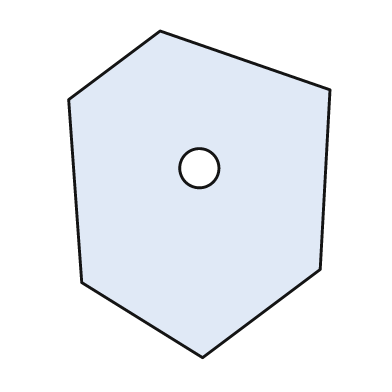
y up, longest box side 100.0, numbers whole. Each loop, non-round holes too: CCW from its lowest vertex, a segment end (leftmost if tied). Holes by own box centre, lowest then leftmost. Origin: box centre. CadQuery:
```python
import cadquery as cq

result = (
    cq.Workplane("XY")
    .moveTo(1.0, -50.0)
    .lineTo(37.0, -23.0)
    .lineTo(40.0, 32.0)
    .lineTo(-12.0, 50.0)
    .lineTo(-40.0, 29.0)
    .lineTo(-36.0, -27.0)
    .close()
    .moveTo(0.0, 8.0)
    .circle(6.0)
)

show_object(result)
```